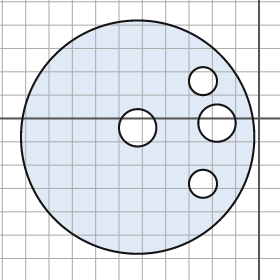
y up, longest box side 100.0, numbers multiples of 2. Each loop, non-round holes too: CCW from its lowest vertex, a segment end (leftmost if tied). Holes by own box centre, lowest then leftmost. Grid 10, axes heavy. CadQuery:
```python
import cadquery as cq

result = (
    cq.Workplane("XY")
    .moveTo(-52.0, -8.0)
    .circle(50.0)
    .moveTo(-24.0, -28.0)
    .circle(6.0)
    .moveTo(-52.0, -4.0)
    .circle(8.0)
    .moveTo(-18.0, -2.0)
    .circle(8.0)
    .moveTo(-24.0, 16.0)
    .circle(6.0)
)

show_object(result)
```